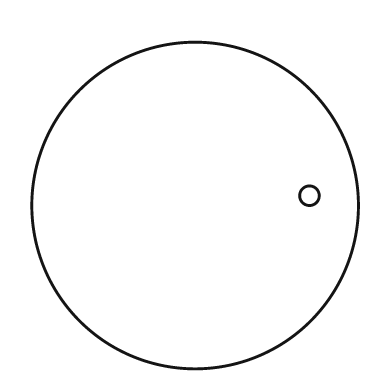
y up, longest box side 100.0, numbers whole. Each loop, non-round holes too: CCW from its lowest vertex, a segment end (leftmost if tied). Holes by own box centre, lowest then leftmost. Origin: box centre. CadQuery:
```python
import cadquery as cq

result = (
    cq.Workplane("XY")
    .moveTo(0.0, 0.0)
    .circle(50.0)
    .moveTo(35.0, 3.0)
    .circle(3.0)
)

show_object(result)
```